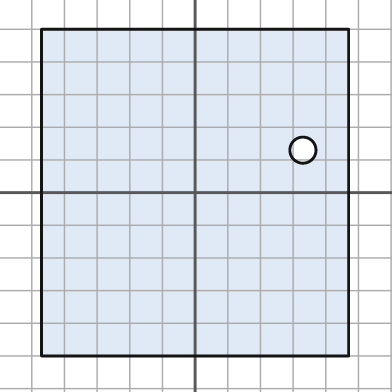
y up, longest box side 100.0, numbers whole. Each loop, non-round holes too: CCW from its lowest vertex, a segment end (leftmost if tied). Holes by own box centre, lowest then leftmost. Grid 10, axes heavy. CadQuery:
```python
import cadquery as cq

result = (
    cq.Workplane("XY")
    .moveTo(-47.0, -50.0)
    .lineTo(47.0, -50.0)
    .lineTo(47.0, 50.0)
    .lineTo(-47.0, 50.0)
    .close()
    .moveTo(33.0, 13.0)
    .circle(4.0)
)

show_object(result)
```